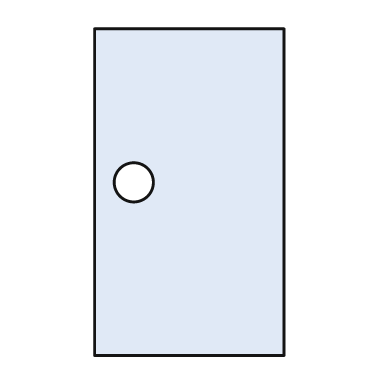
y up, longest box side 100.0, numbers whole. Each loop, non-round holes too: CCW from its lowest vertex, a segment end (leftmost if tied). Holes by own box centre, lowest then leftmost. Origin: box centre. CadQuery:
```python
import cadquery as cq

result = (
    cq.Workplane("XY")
    .moveTo(-29.0, -50.0)
    .lineTo(29.0, -50.0)
    .lineTo(29.0, 50.0)
    .lineTo(-29.0, 50.0)
    .close()
    .moveTo(-17.0, 3.0)
    .circle(6.0)
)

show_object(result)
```